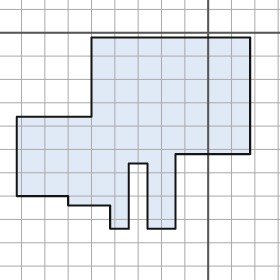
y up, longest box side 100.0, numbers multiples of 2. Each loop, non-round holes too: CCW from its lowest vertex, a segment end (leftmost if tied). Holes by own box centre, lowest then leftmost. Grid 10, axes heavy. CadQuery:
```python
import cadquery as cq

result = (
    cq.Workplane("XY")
    .moveTo(-42.0, -84.0)
    .lineTo(-34.0, -84.0)
    .lineTo(-34.0, -56.0)
    .lineTo(-26.0, -56.0)
    .lineTo(-26.0, -84.0)
    .lineTo(-14.0, -84.0)
    .lineTo(-14.0, -52.0)
    .lineTo(18.0, -52.0)
    .lineTo(18.0, -2.0)
    .lineTo(-50.0, -2.0)
    .lineTo(-50.0, -36.0)
    .lineTo(-82.0, -36.0)
    .lineTo(-82.0, -70.0)
    .lineTo(-60.0, -70.0)
    .lineTo(-60.0, -74.0)
    .lineTo(-42.0, -74.0)
    .close()
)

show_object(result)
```